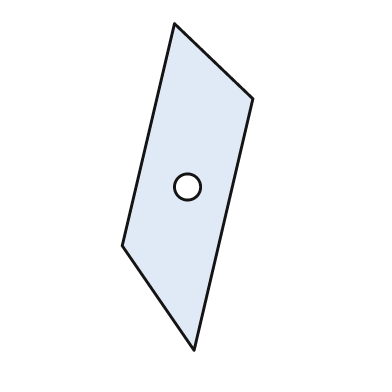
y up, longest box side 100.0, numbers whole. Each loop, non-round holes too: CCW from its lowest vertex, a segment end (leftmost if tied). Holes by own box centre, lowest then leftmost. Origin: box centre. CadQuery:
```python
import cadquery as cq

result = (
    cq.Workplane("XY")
    .moveTo(2.0, -50.0)
    .lineTo(20.0, 27.0)
    .lineTo(-4.0, 50.0)
    .lineTo(-20.0, -18.0)
    .close()
    .moveTo(0.0, 0.0)
    .circle(4.0)
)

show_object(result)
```